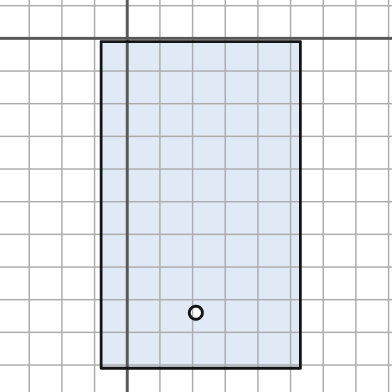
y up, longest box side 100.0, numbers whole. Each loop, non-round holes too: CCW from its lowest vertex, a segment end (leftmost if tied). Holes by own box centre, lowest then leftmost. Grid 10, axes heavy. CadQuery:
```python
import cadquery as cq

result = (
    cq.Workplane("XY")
    .moveTo(-8.0, -101.0)
    .lineTo(53.0, -101.0)
    .lineTo(53.0, -1.0)
    .lineTo(-8.0, -1.0)
    .close()
    .moveTo(21.0, -84.0)
    .circle(2.0)
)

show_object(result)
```